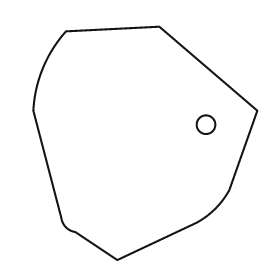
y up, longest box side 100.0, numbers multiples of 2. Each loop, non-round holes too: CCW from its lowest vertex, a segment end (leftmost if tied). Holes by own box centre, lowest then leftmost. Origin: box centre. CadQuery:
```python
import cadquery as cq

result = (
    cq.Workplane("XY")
    .moveTo(-12.0, -50.0)
    .lineTo(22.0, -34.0)
    .threePointArc((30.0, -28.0), (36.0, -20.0))
    .lineTo(48.0, 14.0)
    .lineTo(6.0, 50.0)
    .lineTo(-34.0, 48.0)
    .threePointArc((-44.0, 32.0), (-48.0, 14.0))
    .lineTo(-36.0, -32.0)
    .threePointArc((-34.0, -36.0), (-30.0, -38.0))
    .close()
    .moveTo(26.0, 8.0)
    .circle(4.0)
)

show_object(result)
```